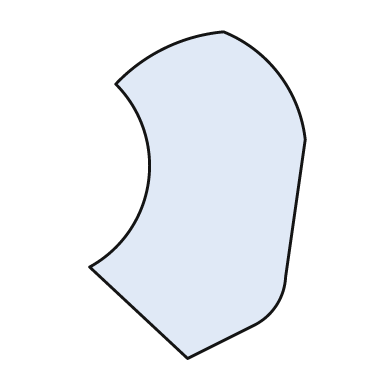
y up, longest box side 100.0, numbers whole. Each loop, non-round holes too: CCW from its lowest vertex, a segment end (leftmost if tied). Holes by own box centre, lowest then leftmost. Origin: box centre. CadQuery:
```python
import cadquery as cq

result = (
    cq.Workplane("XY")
    .moveTo(-3.0, -50.0)
    .lineTo(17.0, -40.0)
    .threePointArc((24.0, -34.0), (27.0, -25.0))
    .lineTo(33.0, 17.0)
    .threePointArc((25.0, 37.0), (8.0, 50.0))
    .threePointArc((-10.0, 45.0), (-25.0, 34.0))
    .threePointArc((-15.0, 4.0), (-33.0, -22.0))
    .close()
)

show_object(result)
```